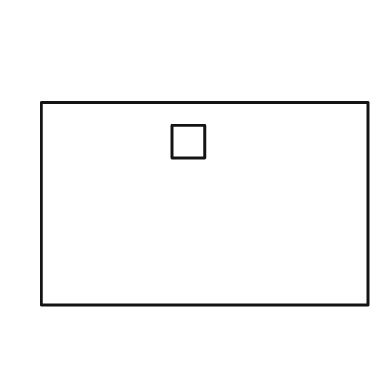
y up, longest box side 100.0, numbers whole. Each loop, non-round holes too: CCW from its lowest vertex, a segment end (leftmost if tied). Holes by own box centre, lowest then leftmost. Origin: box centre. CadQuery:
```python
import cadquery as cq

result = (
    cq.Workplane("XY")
    .moveTo(-50.0, -31.0)
    .lineTo(50.0, -31.0)
    .lineTo(50.0, 31.0)
    .lineTo(-50.0, 31.0)
    .close()
    .moveTo(-10.0, 14.0)
    .lineTo(0.0, 14.0)
    .lineTo(0.0, 24.0)
    .lineTo(-10.0, 24.0)
    .close()
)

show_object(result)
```